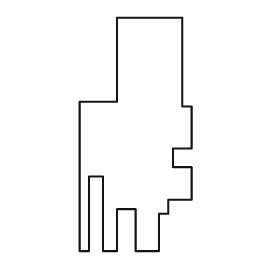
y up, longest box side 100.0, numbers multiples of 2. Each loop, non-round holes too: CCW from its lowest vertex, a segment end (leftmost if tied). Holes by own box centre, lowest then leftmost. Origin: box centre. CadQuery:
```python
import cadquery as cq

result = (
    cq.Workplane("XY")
    .moveTo(-24.0, -50.0)
    .lineTo(-20.0, -50.0)
    .lineTo(-20.0, -18.0)
    .lineTo(-14.0, -18.0)
    .lineTo(-14.0, -50.0)
    .lineTo(-8.0, -50.0)
    .lineTo(-8.0, -32.0)
    .lineTo(0.0, -32.0)
    .lineTo(0.0, -50.0)
    .lineTo(10.0, -50.0)
    .lineTo(10.0, -34.0)
    .lineTo(14.0, -34.0)
    .lineTo(14.0, -28.0)
    .lineTo(24.0, -28.0)
    .lineTo(24.0, -14.0)
    .lineTo(16.0, -14.0)
    .lineTo(16.0, -6.0)
    .lineTo(24.0, -6.0)
    .lineTo(24.0, 12.0)
    .lineTo(20.0, 12.0)
    .lineTo(20.0, 50.0)
    .lineTo(-8.0, 50.0)
    .lineTo(-8.0, 14.0)
    .lineTo(-24.0, 14.0)
    .close()
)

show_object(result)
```